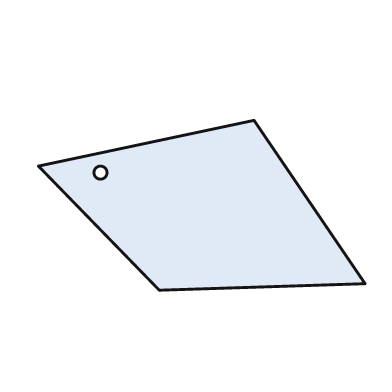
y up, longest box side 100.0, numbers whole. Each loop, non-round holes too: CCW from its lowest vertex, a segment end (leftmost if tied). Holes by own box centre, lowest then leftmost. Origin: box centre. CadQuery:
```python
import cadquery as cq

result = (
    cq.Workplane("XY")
    .moveTo(-13.0, -26.0)
    .lineTo(50.0, -24.0)
    .lineTo(16.0, 26.0)
    .lineTo(-50.0, 12.0)
    .close()
    .moveTo(-31.0, 10.0)
    .circle(2.0)
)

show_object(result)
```